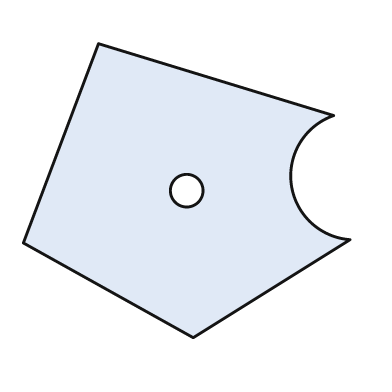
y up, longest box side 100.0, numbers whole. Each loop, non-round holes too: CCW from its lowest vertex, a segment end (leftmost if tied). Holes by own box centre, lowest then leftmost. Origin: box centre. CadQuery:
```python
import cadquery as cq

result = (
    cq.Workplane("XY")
    .moveTo(2.0, -45.0)
    .lineTo(50.0, -15.0)
    .threePointArc((32.0, 2.0), (45.0, 23.0))
    .lineTo(-27.0, 45.0)
    .lineTo(-50.0, -16.0)
    .close()
    .moveTo(0.0, 0.0)
    .circle(5.0)
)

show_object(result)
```